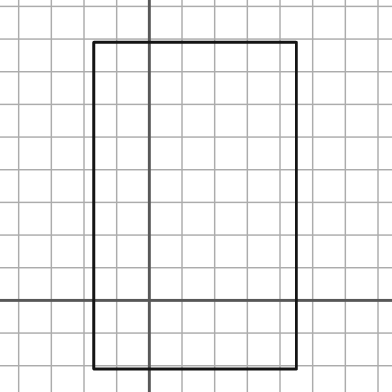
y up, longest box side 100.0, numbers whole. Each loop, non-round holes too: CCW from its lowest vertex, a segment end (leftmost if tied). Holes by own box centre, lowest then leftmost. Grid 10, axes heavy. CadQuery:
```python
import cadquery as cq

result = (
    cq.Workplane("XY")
    .moveTo(-17.0, -21.0)
    .lineTo(45.0, -21.0)
    .lineTo(45.0, 79.0)
    .lineTo(-17.0, 79.0)
    .close()
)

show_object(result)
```